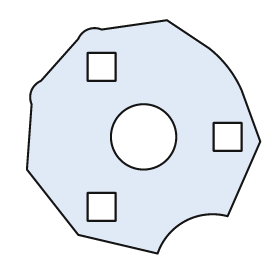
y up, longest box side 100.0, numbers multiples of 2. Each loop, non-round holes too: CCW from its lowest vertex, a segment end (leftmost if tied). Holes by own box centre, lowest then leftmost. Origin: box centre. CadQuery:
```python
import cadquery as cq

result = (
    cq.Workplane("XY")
    .moveTo(6.0, -50.0)
    .threePointArc((18.0, -36.0), (36.0, -34.0))
    .lineTo(50.0, -2.0)
    .lineTo(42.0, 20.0)
    .threePointArc((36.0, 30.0), (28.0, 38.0))
    .lineTo(10.0, 50.0)
    .lineTo(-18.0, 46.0)
    .threePointArc((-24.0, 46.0), (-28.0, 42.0))
    .lineTo(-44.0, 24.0)
    .threePointArc((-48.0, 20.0), (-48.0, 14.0))
    .lineTo(-50.0, -14.0)
    .lineTo(-28.0, -42.0)
    .close()
    .moveTo(-24.0, -36.0)
    .lineTo(-12.0, -36.0)
    .lineTo(-12.0, -24.0)
    .lineTo(-24.0, -24.0)
    .close()
    .moveTo(0.0, 0.0)
    .circle(14.0)
    .moveTo(30.0, -6.0)
    .lineTo(42.0, -6.0)
    .lineTo(42.0, 6.0)
    .lineTo(30.0, 6.0)
    .close()
    .moveTo(-24.0, 24.0)
    .lineTo(-12.0, 24.0)
    .lineTo(-12.0, 36.0)
    .lineTo(-24.0, 36.0)
    .close()
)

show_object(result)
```